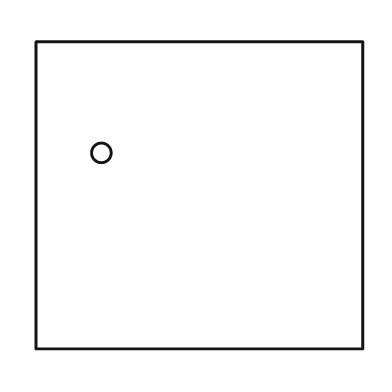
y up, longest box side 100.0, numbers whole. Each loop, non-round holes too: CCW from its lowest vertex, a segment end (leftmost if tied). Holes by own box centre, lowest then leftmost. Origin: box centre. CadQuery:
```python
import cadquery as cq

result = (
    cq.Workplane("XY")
    .moveTo(-50.0, -47.0)
    .lineTo(50.0, -47.0)
    .lineTo(50.0, 47.0)
    .lineTo(-50.0, 47.0)
    .close()
    .moveTo(-30.0, 13.0)
    .circle(3.0)
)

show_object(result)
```